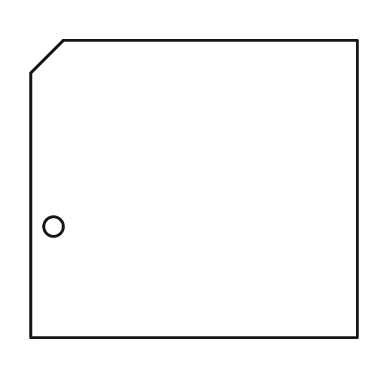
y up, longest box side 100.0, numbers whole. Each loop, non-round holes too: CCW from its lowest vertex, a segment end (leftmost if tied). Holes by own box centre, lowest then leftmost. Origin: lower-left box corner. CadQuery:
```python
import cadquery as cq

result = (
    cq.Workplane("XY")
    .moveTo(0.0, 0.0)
    .lineTo(100.0, 0.0)
    .lineTo(100.0, 91.0)
    .lineTo(10.0, 91.0)
    .lineTo(0.0, 81.0)
    .close()
    .moveTo(7.0, 34.0)
    .circle(3.0)
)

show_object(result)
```